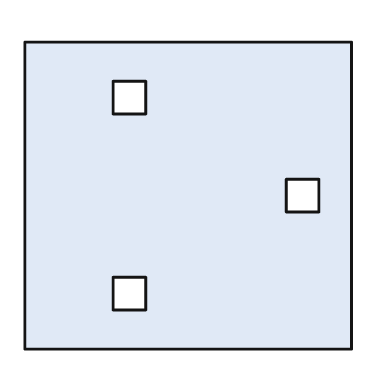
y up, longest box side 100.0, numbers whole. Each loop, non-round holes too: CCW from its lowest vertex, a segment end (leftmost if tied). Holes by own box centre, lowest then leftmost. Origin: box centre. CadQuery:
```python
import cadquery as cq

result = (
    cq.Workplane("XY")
    .moveTo(-50.0, -47.0)
    .lineTo(50.0, -47.0)
    .lineTo(50.0, 47.0)
    .lineTo(-50.0, 47.0)
    .close()
    .moveTo(-23.0, -35.0)
    .lineTo(-13.0, -35.0)
    .lineTo(-13.0, -25.0)
    .lineTo(-23.0, -25.0)
    .close()
    .moveTo(30.0, -5.0)
    .lineTo(40.0, -5.0)
    .lineTo(40.0, 5.0)
    .lineTo(30.0, 5.0)
    .close()
    .moveTo(-23.0, 25.0)
    .lineTo(-13.0, 25.0)
    .lineTo(-13.0, 35.0)
    .lineTo(-23.0, 35.0)
    .close()
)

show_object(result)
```